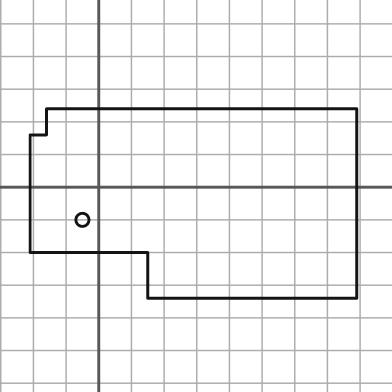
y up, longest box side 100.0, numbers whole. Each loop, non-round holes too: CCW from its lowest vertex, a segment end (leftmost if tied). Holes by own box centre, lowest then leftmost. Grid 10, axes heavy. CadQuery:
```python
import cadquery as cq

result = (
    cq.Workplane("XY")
    .moveTo(15.0, -34.0)
    .lineTo(79.0, -34.0)
    .lineTo(79.0, 24.0)
    .lineTo(-16.0, 24.0)
    .lineTo(-16.0, 16.0)
    .lineTo(-21.0, 16.0)
    .lineTo(-21.0, -20.0)
    .lineTo(15.0, -20.0)
    .close()
    .moveTo(-5.0, -10.0)
    .circle(2.0)
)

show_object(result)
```